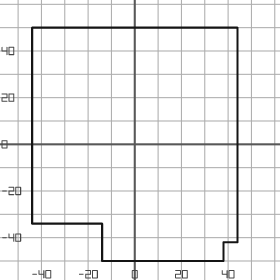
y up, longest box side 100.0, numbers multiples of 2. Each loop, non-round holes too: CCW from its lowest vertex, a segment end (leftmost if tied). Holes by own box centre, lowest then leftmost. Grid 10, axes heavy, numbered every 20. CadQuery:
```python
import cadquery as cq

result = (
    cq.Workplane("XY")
    .moveTo(-14.0, -50.0)
    .lineTo(38.0, -50.0)
    .lineTo(38.0, -42.0)
    .lineTo(44.0, -42.0)
    .lineTo(44.0, 50.0)
    .lineTo(-44.0, 50.0)
    .lineTo(-44.0, -34.0)
    .lineTo(-14.0, -34.0)
    .close()
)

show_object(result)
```